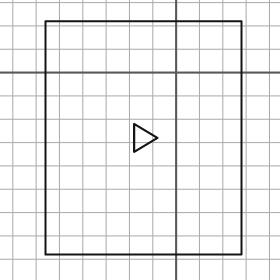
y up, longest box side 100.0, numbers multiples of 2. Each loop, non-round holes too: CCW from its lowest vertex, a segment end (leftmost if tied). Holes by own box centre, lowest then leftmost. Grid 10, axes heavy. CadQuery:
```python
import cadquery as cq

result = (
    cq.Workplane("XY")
    .moveTo(-56.0, -78.0)
    .lineTo(28.0, -78.0)
    .lineTo(28.0, 22.0)
    .lineTo(-56.0, 22.0)
    .close()
    .moveTo(-18.0, -34.0)
    .lineTo(-8.0, -28.0)
    .lineTo(-18.0, -22.0)
    .close()
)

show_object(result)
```